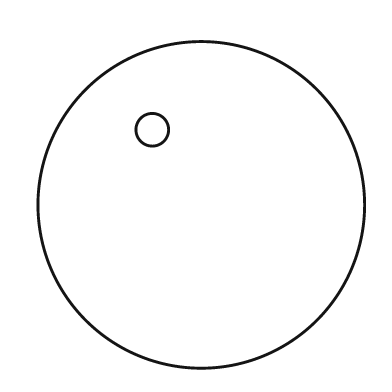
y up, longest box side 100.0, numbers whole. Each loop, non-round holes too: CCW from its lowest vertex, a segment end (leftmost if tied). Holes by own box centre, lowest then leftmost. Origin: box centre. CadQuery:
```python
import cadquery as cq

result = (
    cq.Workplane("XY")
    .moveTo(0.0, 0.0)
    .circle(50.0)
    .moveTo(-15.0, 23.0)
    .circle(5.0)
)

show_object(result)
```